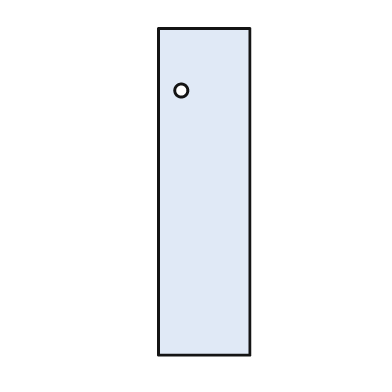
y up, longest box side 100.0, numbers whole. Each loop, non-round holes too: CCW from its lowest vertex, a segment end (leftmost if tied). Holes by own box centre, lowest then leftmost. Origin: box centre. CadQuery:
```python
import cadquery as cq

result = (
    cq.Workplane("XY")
    .moveTo(-14.0, -50.0)
    .lineTo(14.0, -50.0)
    .lineTo(14.0, 50.0)
    .lineTo(-14.0, 50.0)
    .close()
    .moveTo(-7.0, 31.0)
    .circle(2.0)
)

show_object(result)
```